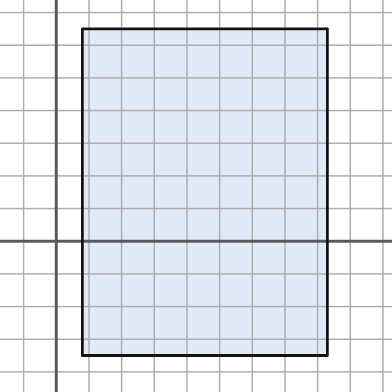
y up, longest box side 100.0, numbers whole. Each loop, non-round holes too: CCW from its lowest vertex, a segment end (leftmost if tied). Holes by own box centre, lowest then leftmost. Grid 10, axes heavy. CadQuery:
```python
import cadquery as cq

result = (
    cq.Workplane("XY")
    .moveTo(8.0, -35.0)
    .lineTo(83.0, -35.0)
    .lineTo(83.0, 65.0)
    .lineTo(8.0, 65.0)
    .close()
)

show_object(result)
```